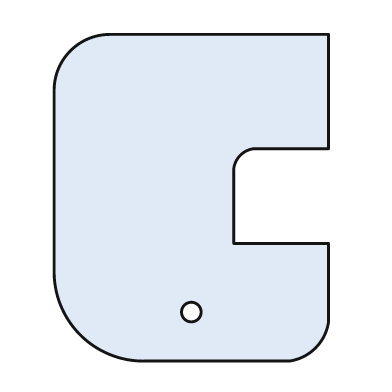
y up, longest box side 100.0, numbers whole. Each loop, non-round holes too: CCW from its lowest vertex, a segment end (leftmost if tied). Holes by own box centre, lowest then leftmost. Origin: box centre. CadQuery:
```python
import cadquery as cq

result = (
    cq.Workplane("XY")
    .moveTo(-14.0, -50.0)
    .lineTo(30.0, -50.0)
    .threePointArc((38.0, -46.0), (42.0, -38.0))
    .lineTo(42.0, -14.0)
    .lineTo(13.0, -14.0)
    .lineTo(13.0, 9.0)
    .threePointArc((15.0, 13.0), (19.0, 15.0))
    .lineTo(42.0, 15.0)
    .lineTo(42.0, 50.0)
    .lineTo(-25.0, 50.0)
    .threePointArc((-37.0, 45.0), (-42.0, 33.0))
    .lineTo(-42.0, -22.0)
    .threePointArc((-34.0, -42.0), (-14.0, -50.0))
    .close()
    .moveTo(0.0, -35.0)
    .circle(3.0)
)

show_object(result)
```